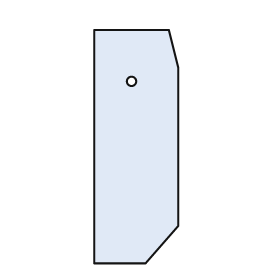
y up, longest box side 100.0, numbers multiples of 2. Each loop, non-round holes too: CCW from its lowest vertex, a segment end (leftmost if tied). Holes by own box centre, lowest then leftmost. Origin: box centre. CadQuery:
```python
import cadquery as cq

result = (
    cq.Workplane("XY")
    .moveTo(-18.0, -50.0)
    .lineTo(4.0, -50.0)
    .lineTo(18.0, -34.0)
    .lineTo(18.0, 34.0)
    .lineTo(14.0, 50.0)
    .lineTo(-18.0, 50.0)
    .close()
    .moveTo(-2.0, 28.0)
    .circle(2.0)
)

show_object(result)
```